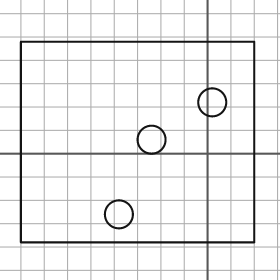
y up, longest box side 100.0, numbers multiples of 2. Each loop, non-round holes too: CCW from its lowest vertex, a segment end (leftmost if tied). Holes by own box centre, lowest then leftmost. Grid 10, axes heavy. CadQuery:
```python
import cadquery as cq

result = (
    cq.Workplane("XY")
    .moveTo(-80.0, -38.0)
    .lineTo(20.0, -38.0)
    .lineTo(20.0, 48.0)
    .lineTo(-80.0, 48.0)
    .close()
    .moveTo(-38.0, -26.0)
    .circle(6.0)
    .moveTo(-24.0, 6.0)
    .circle(6.0)
    .moveTo(2.0, 22.0)
    .circle(6.0)
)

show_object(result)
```